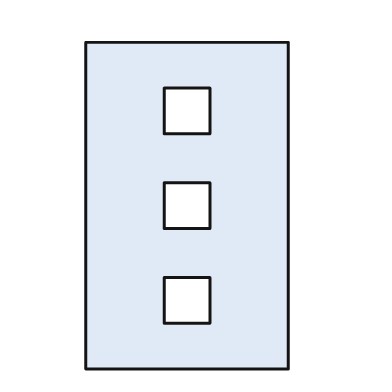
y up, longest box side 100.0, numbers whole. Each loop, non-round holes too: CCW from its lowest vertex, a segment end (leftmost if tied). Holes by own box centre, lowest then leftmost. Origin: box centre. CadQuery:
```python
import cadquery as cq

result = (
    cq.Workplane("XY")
    .moveTo(-31.0, -50.0)
    .lineTo(31.0, -50.0)
    .lineTo(31.0, 50.0)
    .lineTo(-31.0, 50.0)
    .close()
    .moveTo(-7.0, -36.0)
    .lineTo(7.0, -36.0)
    .lineTo(7.0, -22.0)
    .lineTo(-7.0, -22.0)
    .close()
    .moveTo(-7.0, -7.0)
    .lineTo(7.0, -7.0)
    .lineTo(7.0, 7.0)
    .lineTo(-7.0, 7.0)
    .close()
    .moveTo(-7.0, 22.0)
    .lineTo(7.0, 22.0)
    .lineTo(7.0, 36.0)
    .lineTo(-7.0, 36.0)
    .close()
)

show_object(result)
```